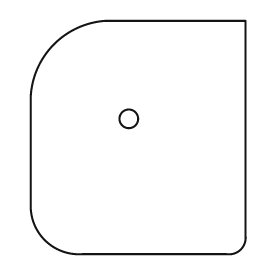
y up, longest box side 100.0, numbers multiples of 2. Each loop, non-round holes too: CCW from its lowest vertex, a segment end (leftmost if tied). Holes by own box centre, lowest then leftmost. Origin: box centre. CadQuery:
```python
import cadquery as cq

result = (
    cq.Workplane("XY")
    .moveTo(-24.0, -50.0)
    .lineTo(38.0, -50.0)
    .threePointArc((44.0, -48.0), (46.0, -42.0))
    .lineTo(46.0, 50.0)
    .lineTo(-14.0, 50.0)
    .threePointArc((-36.0, 40.0), (-46.0, 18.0))
    .lineTo(-46.0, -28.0)
    .threePointArc((-40.0, -44.0), (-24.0, -50.0))
    .close()
    .moveTo(-4.0, 8.0)
    .circle(4.0)
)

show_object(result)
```